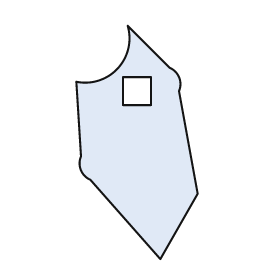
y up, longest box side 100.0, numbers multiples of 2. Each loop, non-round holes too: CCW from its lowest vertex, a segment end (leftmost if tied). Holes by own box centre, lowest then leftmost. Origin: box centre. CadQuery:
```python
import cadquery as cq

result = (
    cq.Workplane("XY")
    .moveTo(10.0, -50.0)
    .lineTo(26.0, -22.0)
    .lineTo(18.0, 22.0)
    .threePointArc((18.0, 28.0), (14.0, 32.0))
    .lineTo(-4.0, 50.0)
    .threePointArc((-8.0, 32.0), (-26.0, 26.0))
    .lineTo(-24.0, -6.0)
    .threePointArc((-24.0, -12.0), (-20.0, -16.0))
    .close()
    .moveTo(-6.0, 16.0)
    .lineTo(6.0, 16.0)
    .lineTo(6.0, 28.0)
    .lineTo(-6.0, 28.0)
    .close()
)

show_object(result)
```